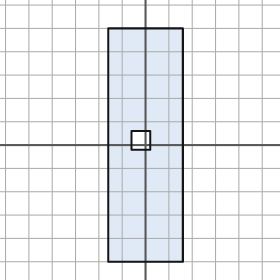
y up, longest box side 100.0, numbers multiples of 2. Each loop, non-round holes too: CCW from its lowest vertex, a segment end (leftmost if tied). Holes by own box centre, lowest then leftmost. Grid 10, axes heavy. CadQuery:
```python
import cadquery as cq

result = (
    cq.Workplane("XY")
    .moveTo(-16.0, -50.0)
    .lineTo(16.0, -50.0)
    .lineTo(16.0, 50.0)
    .lineTo(-16.0, 50.0)
    .close()
    .moveTo(-6.0, -2.0)
    .lineTo(2.0, -2.0)
    .lineTo(2.0, 6.0)
    .lineTo(-6.0, 6.0)
    .close()
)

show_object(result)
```